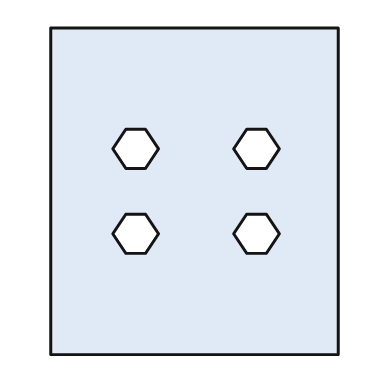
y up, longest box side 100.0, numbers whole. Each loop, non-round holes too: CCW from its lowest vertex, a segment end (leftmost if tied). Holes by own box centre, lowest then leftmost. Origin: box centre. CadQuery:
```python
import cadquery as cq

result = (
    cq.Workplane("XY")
    .moveTo(-44.0, -50.0)
    .lineTo(44.0, -50.0)
    .lineTo(44.0, 50.0)
    .lineTo(-44.0, 50.0)
    .close()
    .moveTo(-21.0, -19.0)
    .lineTo(-15.0, -19.0)
    .lineTo(-11.0, -13.0)
    .lineTo(-15.0, -7.0)
    .lineTo(-21.0, -7.0)
    .lineTo(-25.0, -13.0)
    .close()
    .moveTo(16.0, -19.0)
    .lineTo(22.0, -19.0)
    .lineTo(26.0, -13.0)
    .lineTo(22.0, -7.0)
    .lineTo(16.0, -7.0)
    .lineTo(12.0, -13.0)
    .close()
    .moveTo(-21.0, 7.0)
    .lineTo(-15.0, 7.0)
    .lineTo(-11.0, 13.0)
    .lineTo(-15.0, 19.0)
    .lineTo(-21.0, 19.0)
    .lineTo(-25.0, 13.0)
    .close()
    .moveTo(16.0, 7.0)
    .lineTo(22.0, 7.0)
    .lineTo(26.0, 13.0)
    .lineTo(22.0, 19.0)
    .lineTo(16.0, 19.0)
    .lineTo(12.0, 13.0)
    .close()
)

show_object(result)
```